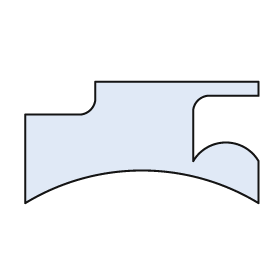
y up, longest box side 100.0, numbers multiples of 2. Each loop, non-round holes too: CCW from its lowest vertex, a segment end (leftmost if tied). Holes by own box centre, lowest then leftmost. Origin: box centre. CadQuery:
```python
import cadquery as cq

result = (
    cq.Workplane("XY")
    .moveTo(-50.0, -26.0)
    .threePointArc((0.0, -12.0), (50.0, -26.0))
    .lineTo(50.0, -8.0)
    .threePointArc((36.0, 0.0), (22.0, -8.0))
    .lineTo(22.0, 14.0)
    .threePointArc((24.0, 18.0), (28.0, 20.0))
    .lineTo(50.0, 20.0)
    .lineTo(50.0, 26.0)
    .lineTo(-20.0, 26.0)
    .lineTo(-20.0, 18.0)
    .threePointArc((-22.0, 14.0), (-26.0, 12.0))
    .lineTo(-50.0, 12.0)
    .close()
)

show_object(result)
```